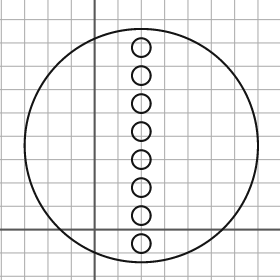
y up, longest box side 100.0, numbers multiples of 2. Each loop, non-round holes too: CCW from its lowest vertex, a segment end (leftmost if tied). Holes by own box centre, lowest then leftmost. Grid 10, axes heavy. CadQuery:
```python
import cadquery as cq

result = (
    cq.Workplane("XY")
    .moveTo(20.0, 36.0)
    .circle(50.0)
    .moveTo(20.0, -6.0)
    .circle(4.0)
    .moveTo(20.0, 6.0)
    .circle(4.0)
    .moveTo(20.0, 18.0)
    .circle(4.0)
    .moveTo(20.0, 30.0)
    .circle(4.0)
    .moveTo(20.0, 42.0)
    .circle(4.0)
    .moveTo(20.0, 54.0)
    .circle(4.0)
    .moveTo(20.0, 66.0)
    .circle(4.0)
    .moveTo(20.0, 78.0)
    .circle(4.0)
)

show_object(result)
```